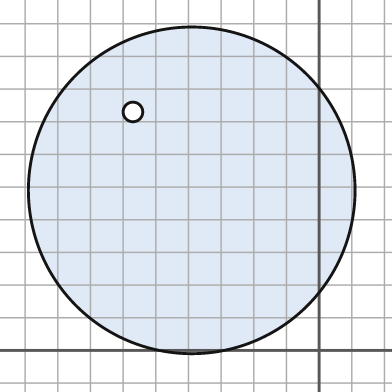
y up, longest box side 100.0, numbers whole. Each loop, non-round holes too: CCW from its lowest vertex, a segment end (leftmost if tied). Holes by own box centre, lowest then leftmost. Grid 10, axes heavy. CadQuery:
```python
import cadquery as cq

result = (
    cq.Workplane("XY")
    .moveTo(-39.0, 49.0)
    .circle(50.0)
    .moveTo(-57.0, 73.0)
    .circle(3.0)
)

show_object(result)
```